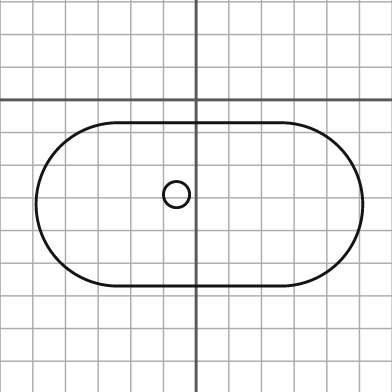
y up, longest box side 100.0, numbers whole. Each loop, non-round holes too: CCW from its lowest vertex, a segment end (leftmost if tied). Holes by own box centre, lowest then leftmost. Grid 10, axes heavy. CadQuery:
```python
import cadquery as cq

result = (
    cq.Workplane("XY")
    .moveTo(-24.0, -57.0)
    .lineTo(26.0, -57.0)
    .threePointArc((51.0, -32.0), (26.0, -7.0))
    .lineTo(-24.0, -7.0)
    .threePointArc((-49.0, -32.0), (-24.0, -57.0))
    .close()
    .moveTo(-6.0, -29.0)
    .circle(4.0)
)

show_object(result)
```